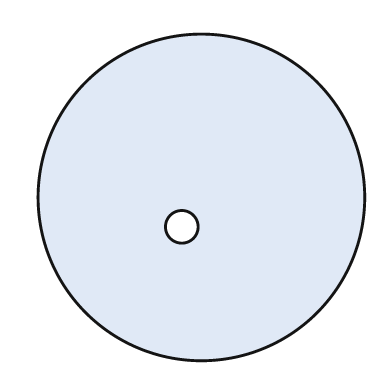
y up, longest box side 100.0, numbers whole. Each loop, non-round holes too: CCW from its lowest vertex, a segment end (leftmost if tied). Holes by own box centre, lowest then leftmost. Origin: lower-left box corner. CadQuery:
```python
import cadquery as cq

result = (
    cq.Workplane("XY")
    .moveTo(50.0, 50.0)
    .circle(50.0)
    .moveTo(44.0, 41.0)
    .circle(5.0)
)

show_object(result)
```